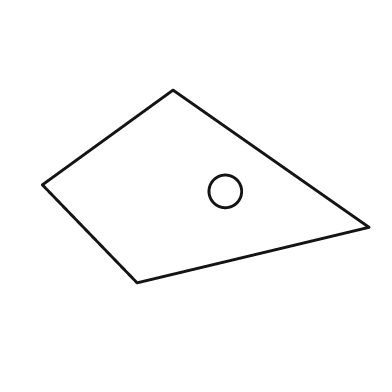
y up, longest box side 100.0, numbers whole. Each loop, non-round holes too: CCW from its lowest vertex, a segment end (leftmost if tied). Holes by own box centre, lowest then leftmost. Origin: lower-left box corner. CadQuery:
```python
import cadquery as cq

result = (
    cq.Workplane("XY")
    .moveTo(29.0, 0.0)
    .lineTo(100.0, 17.0)
    .lineTo(40.0, 59.0)
    .lineTo(0.0, 30.0)
    .close()
    .moveTo(56.0, 28.0)
    .circle(5.0)
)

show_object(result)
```